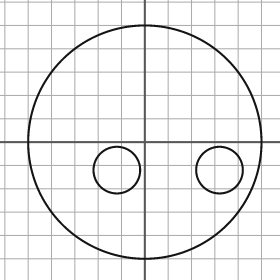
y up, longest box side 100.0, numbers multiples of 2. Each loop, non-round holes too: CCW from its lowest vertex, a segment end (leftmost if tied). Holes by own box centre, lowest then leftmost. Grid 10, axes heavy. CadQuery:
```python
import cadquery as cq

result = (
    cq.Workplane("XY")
    .moveTo(0.0, 0.0)
    .circle(50.0)
    .moveTo(-12.0, -12.0)
    .circle(10.0)
    .moveTo(32.0, -12.0)
    .circle(10.0)
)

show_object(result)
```